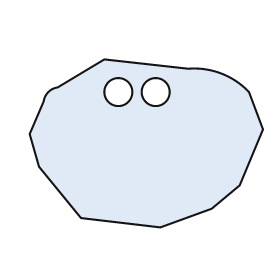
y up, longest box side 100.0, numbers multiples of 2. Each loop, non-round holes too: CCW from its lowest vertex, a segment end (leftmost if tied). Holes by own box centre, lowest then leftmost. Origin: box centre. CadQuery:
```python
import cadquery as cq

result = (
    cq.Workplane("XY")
    .moveTo(6.0, -36.0)
    .lineTo(28.0, -28.0)
    .lineTo(40.0, -18.0)
    .lineTo(50.0, 6.0)
    .lineTo(44.0, 22.0)
    .threePointArc((32.0, 30.0), (18.0, 32.0))
    .lineTo(-18.0, 36.0)
    .lineTo(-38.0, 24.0)
    .threePointArc((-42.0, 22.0), (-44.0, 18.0))
    .lineTo(-50.0, 4.0)
    .lineTo(-46.0, -10.0)
    .lineTo(-28.0, -32.0)
    .close()
    .moveTo(-12.0, 22.0)
    .circle(6.0)
    .moveTo(4.0, 22.0)
    .circle(6.0)
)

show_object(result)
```